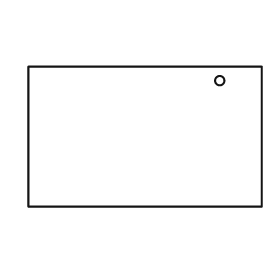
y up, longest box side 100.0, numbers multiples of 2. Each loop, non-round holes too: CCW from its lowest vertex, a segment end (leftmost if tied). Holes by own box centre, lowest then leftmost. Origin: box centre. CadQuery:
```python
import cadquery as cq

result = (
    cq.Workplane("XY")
    .moveTo(-50.0, -30.0)
    .lineTo(50.0, -30.0)
    .lineTo(50.0, 30.0)
    .lineTo(-50.0, 30.0)
    .close()
    .moveTo(32.0, 24.0)
    .circle(2.0)
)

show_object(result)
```